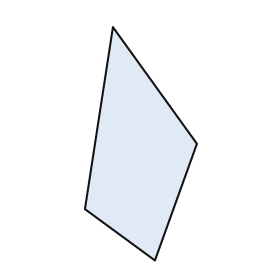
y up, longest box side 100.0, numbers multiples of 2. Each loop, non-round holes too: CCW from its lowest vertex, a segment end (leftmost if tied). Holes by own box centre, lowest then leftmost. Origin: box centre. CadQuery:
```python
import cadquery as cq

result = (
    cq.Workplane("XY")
    .moveTo(6.0, -50.0)
    .lineTo(24.0, 0.0)
    .lineTo(-12.0, 50.0)
    .lineTo(-24.0, -28.0)
    .close()
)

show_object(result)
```